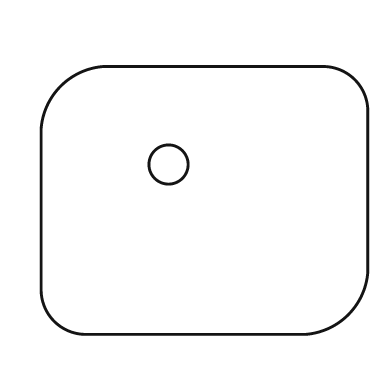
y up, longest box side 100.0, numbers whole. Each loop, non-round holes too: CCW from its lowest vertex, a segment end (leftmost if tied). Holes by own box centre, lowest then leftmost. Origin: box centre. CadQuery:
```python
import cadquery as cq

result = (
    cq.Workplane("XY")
    .moveTo(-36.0, -41.0)
    .lineTo(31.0, -41.0)
    .threePointArc((44.0, -35.0), (50.0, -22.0))
    .lineTo(50.0, 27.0)
    .threePointArc((46.0, 37.0), (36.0, 41.0))
    .lineTo(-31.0, 41.0)
    .threePointArc((-44.0, 35.0), (-50.0, 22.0))
    .lineTo(-50.0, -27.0)
    .threePointArc((-46.0, -37.0), (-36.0, -41.0))
    .close()
    .moveTo(-11.0, 11.0)
    .circle(6.0)
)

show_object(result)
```